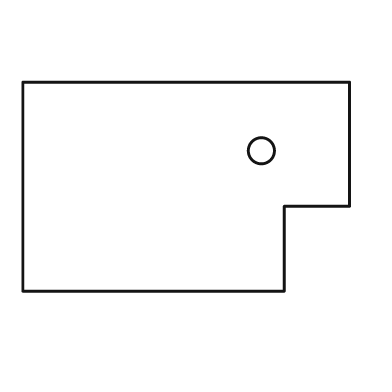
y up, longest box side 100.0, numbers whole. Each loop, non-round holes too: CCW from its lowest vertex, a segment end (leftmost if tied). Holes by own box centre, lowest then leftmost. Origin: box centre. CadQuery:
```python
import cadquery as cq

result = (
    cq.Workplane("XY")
    .moveTo(-50.0, -32.0)
    .lineTo(30.0, -32.0)
    .lineTo(30.0, -6.0)
    .lineTo(50.0, -6.0)
    .lineTo(50.0, 32.0)
    .lineTo(-50.0, 32.0)
    .close()
    .moveTo(23.0, 11.0)
    .circle(4.0)
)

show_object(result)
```